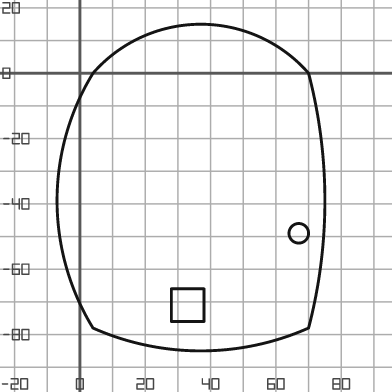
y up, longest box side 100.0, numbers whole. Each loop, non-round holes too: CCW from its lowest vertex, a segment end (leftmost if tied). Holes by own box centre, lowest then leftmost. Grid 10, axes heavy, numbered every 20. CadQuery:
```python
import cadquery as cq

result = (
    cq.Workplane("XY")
    .moveTo(4.0, -78.0)
    .threePointArc((37.0, -85.0), (70.0, -78.0))
    .threePointArc((75.0, -39.0), (70.0, 0.0))
    .threePointArc((37.0, 15.0), (4.0, 0.0))
    .threePointArc((-7.0, -39.0), (4.0, -78.0))
    .close()
    .moveTo(28.0, -76.0)
    .lineTo(38.0, -76.0)
    .lineTo(38.0, -66.0)
    .lineTo(28.0, -66.0)
    .close()
    .moveTo(67.0, -49.0)
    .circle(3.0)
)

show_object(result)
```